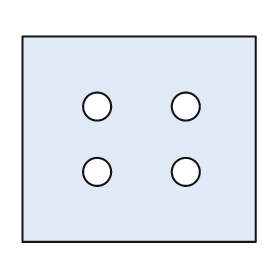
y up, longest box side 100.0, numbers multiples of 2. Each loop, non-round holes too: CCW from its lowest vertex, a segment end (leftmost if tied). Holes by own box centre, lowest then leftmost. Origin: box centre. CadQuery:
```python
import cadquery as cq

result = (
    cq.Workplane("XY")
    .moveTo(-50.0, -44.0)
    .lineTo(50.0, -44.0)
    .lineTo(50.0, 44.0)
    .lineTo(-50.0, 44.0)
    .close()
    .moveTo(-18.0, -14.0)
    .circle(6.0)
    .moveTo(20.0, -14.0)
    .circle(6.0)
    .moveTo(-18.0, 14.0)
    .circle(6.0)
    .moveTo(20.0, 14.0)
    .circle(6.0)
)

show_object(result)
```